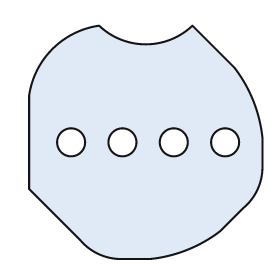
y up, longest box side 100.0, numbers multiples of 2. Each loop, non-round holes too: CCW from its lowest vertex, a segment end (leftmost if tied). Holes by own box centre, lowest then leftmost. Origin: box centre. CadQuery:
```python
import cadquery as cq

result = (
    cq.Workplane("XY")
    .moveTo(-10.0, -50.0)
    .lineTo(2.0, -50.0)
    .threePointArc((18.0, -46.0), (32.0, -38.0))
    .lineTo(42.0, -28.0)
    .threePointArc((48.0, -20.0), (50.0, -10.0))
    .lineTo(50.0, 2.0)
    .threePointArc((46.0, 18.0), (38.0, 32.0))
    .lineTo(20.0, 50.0)
    .threePointArc((0.0, 42.0), (-20.0, 50.0))
    .threePointArc((-40.0, 40.0), (-50.0, 20.0))
    .lineTo(-50.0, -20.0)
    .lineTo(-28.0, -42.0)
    .threePointArc((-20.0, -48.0), (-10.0, -50.0))
    .close()
    .moveTo(-32.0, 0.0)
    .circle(6.0)
    .moveTo(-10.0, 0.0)
    .circle(6.0)
    .moveTo(12.0, 0.0)
    .circle(6.0)
    .moveTo(34.0, 0.0)
    .circle(6.0)
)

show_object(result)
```